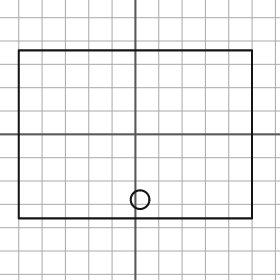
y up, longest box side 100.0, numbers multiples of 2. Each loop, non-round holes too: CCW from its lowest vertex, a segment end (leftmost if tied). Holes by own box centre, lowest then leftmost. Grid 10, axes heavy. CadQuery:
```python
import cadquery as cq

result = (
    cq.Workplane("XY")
    .moveTo(-50.0, -36.0)
    .lineTo(50.0, -36.0)
    .lineTo(50.0, 36.0)
    .lineTo(-50.0, 36.0)
    .close()
    .moveTo(2.0, -28.0)
    .circle(4.0)
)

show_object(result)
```